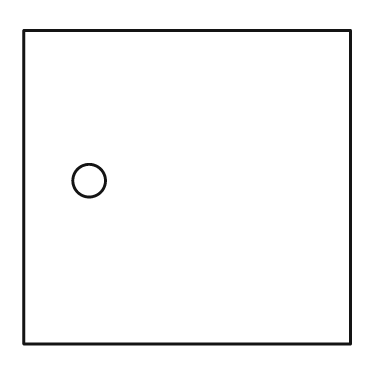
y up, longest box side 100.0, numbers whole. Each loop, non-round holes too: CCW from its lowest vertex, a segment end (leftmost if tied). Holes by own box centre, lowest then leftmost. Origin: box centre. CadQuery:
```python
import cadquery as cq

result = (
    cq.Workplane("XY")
    .moveTo(-50.0, -48.0)
    .lineTo(50.0, -48.0)
    .lineTo(50.0, 48.0)
    .lineTo(-50.0, 48.0)
    .close()
    .moveTo(-30.0, 2.0)
    .circle(5.0)
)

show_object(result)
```